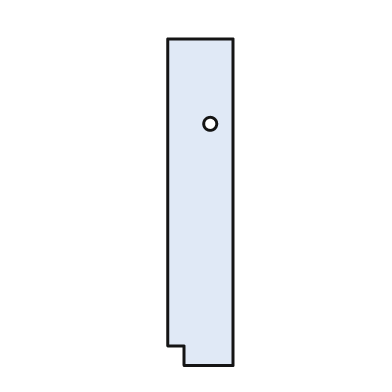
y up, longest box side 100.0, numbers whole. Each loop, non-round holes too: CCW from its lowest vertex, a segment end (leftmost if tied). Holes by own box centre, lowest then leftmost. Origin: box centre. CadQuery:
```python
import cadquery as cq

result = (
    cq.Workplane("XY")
    .moveTo(-5.0, -50.0)
    .lineTo(10.0, -50.0)
    .lineTo(10.0, 50.0)
    .lineTo(-10.0, 50.0)
    .lineTo(-10.0, -44.0)
    .lineTo(-5.0, -44.0)
    .close()
    .moveTo(3.0, 24.0)
    .circle(2.0)
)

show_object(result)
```